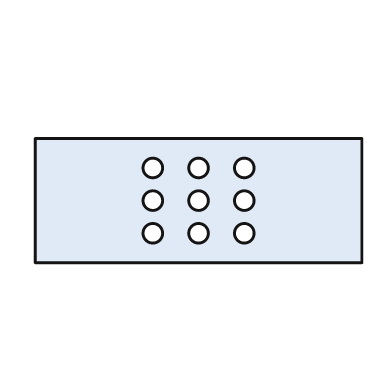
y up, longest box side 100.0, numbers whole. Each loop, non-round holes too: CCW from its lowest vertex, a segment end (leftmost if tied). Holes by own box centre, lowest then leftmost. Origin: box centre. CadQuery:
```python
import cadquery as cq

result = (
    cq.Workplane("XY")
    .moveTo(-50.0, -19.0)
    .lineTo(50.0, -19.0)
    .lineTo(50.0, 19.0)
    .lineTo(-50.0, 19.0)
    .close()
    .moveTo(-14.0, -10.0)
    .circle(3.0)
    .moveTo(0.0, -10.0)
    .circle(3.0)
    .moveTo(14.0, -10.0)
    .circle(3.0)
    .moveTo(-14.0, 0.0)
    .circle(3.0)
    .moveTo(0.0, 0.0)
    .circle(3.0)
    .moveTo(14.0, 0.0)
    .circle(3.0)
    .moveTo(-14.0, 10.0)
    .circle(3.0)
    .moveTo(0.0, 10.0)
    .circle(3.0)
    .moveTo(14.0, 10.0)
    .circle(3.0)
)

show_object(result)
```